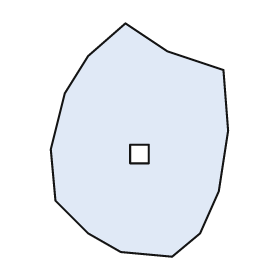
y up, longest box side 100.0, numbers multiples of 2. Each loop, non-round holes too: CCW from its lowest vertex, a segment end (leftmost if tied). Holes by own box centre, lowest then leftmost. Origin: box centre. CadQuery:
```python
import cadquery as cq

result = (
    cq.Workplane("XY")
    .moveTo(14.0, -50.0)
    .lineTo(26.0, -40.0)
    .lineTo(34.0, -22.0)
    .lineTo(38.0, 4.0)
    .lineTo(36.0, 30.0)
    .lineTo(12.0, 38.0)
    .lineTo(-6.0, 50.0)
    .lineTo(-22.0, 36.0)
    .lineTo(-32.0, 20.0)
    .lineTo(-38.0, -4.0)
    .lineTo(-36.0, -26.0)
    .lineTo(-22.0, -40.0)
    .lineTo(-8.0, -48.0)
    .close()
    .moveTo(-4.0, -10.0)
    .lineTo(4.0, -10.0)
    .lineTo(4.0, -2.0)
    .lineTo(-4.0, -2.0)
    .close()
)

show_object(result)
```